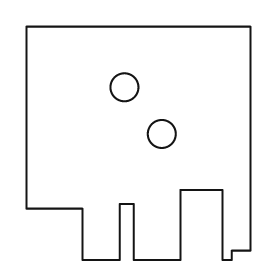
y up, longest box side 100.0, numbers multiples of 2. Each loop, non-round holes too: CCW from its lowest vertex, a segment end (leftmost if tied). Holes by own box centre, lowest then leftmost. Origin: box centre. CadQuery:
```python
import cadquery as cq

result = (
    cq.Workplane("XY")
    .moveTo(-24.0, -50.0)
    .lineTo(-8.0, -50.0)
    .lineTo(-8.0, -26.0)
    .lineTo(-2.0, -26.0)
    .lineTo(-2.0, -50.0)
    .lineTo(18.0, -50.0)
    .lineTo(18.0, -20.0)
    .lineTo(36.0, -20.0)
    .lineTo(36.0, -50.0)
    .lineTo(40.0, -50.0)
    .lineTo(40.0, -46.0)
    .lineTo(48.0, -46.0)
    .lineTo(48.0, 50.0)
    .lineTo(-48.0, 50.0)
    .lineTo(-48.0, -28.0)
    .lineTo(-24.0, -28.0)
    .close()
    .moveTo(10.0, 4.0)
    .circle(6.0)
    .moveTo(-6.0, 24.0)
    .circle(6.0)
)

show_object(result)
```